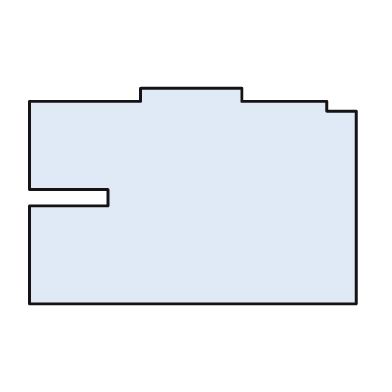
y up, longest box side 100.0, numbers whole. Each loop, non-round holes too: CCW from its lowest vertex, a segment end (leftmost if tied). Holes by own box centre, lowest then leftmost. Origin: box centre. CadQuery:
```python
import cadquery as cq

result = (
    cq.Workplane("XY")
    .moveTo(-50.0, -33.0)
    .lineTo(50.0, -33.0)
    .lineTo(50.0, 26.0)
    .lineTo(41.0, 26.0)
    .lineTo(41.0, 29.0)
    .lineTo(15.0, 29.0)
    .lineTo(15.0, 33.0)
    .lineTo(-16.0, 33.0)
    .lineTo(-16.0, 29.0)
    .lineTo(-50.0, 29.0)
    .lineTo(-50.0, 2.0)
    .lineTo(-26.0, 2.0)
    .lineTo(-26.0, -3.0)
    .lineTo(-50.0, -3.0)
    .close()
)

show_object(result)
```